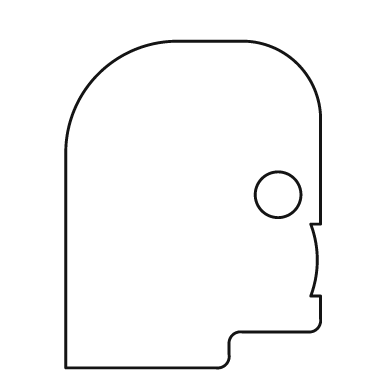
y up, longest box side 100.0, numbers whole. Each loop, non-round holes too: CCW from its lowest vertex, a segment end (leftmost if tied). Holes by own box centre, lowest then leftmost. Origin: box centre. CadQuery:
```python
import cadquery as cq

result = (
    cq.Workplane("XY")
    .moveTo(-39.0, -50.0)
    .lineTo(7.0, -50.0)
    .threePointArc((10.0, -49.0), (11.0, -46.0))
    .lineTo(11.0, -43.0)
    .threePointArc((12.0, -40.0), (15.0, -39.0))
    .lineTo(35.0, -39.0)
    .threePointArc((38.0, -38.0), (39.0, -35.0))
    .lineTo(39.0, -28.0)
    .lineTo(36.0, -28.0)
    .threePointArc((38.0, -17.0), (36.0, -6.0))
    .lineTo(39.0, -6.0)
    .lineTo(39.0, 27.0)
    .threePointArc((32.0, 43.0), (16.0, 50.0))
    .lineTo(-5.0, 50.0)
    .threePointArc((-29.0, 40.0), (-39.0, 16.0))
    .close()
    .moveTo(26.0, 3.0)
    .circle(7.0)
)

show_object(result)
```